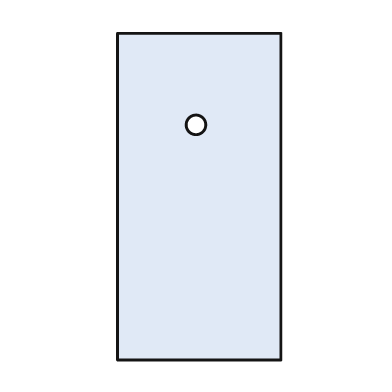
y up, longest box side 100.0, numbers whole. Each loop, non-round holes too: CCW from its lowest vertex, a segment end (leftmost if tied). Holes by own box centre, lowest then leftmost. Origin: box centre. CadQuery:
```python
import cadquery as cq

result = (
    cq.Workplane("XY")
    .moveTo(-25.0, -50.0)
    .lineTo(25.0, -50.0)
    .lineTo(25.0, 50.0)
    .lineTo(-25.0, 50.0)
    .close()
    .moveTo(-1.0, 22.0)
    .circle(3.0)
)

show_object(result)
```